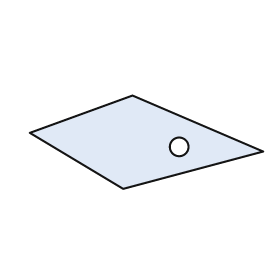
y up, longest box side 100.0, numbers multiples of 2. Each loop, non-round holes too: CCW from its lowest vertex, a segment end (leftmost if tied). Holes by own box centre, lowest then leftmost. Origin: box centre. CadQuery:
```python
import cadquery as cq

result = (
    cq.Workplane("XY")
    .moveTo(-10.0, -20.0)
    .lineTo(50.0, -4.0)
    .lineTo(-6.0, 20.0)
    .lineTo(-50.0, 4.0)
    .close()
    .moveTo(14.0, -2.0)
    .circle(4.0)
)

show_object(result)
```